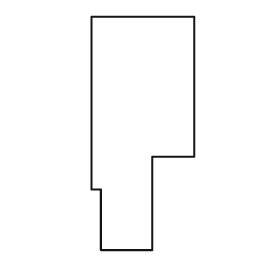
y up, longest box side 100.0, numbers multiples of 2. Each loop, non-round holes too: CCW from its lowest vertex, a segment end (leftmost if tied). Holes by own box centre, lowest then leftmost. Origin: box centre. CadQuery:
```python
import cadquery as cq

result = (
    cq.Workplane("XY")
    .moveTo(-18.0, -50.0)
    .lineTo(4.0, -50.0)
    .lineTo(4.0, -10.0)
    .lineTo(22.0, -10.0)
    .lineTo(22.0, 50.0)
    .lineTo(-22.0, 50.0)
    .lineTo(-22.0, -24.0)
    .lineTo(-18.0, -24.0)
    .close()
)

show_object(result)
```